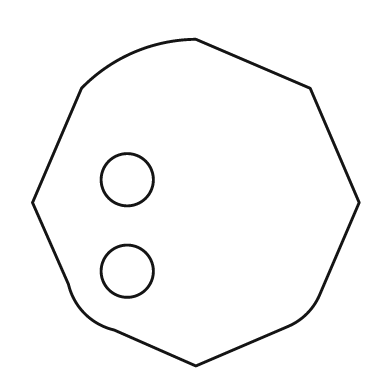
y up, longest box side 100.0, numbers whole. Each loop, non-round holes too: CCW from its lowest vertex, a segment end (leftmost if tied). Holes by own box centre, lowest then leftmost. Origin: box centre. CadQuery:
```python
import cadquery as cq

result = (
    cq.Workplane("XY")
    .moveTo(0.0, -50.0)
    .lineTo(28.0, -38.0)
    .threePointArc((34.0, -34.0), (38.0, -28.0))
    .lineTo(50.0, 0.0)
    .lineTo(35.0, 35.0)
    .lineTo(0.0, 50.0)
    .threePointArc((-19.0, 46.0), (-35.0, 35.0))
    .lineTo(-50.0, 0.0)
    .lineTo(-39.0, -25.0)
    .threePointArc((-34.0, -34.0), (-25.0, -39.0))
    .close()
    .moveTo(-21.0, -21.0)
    .circle(8.0)
    .moveTo(-21.0, 7.0)
    .circle(8.0)
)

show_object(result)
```